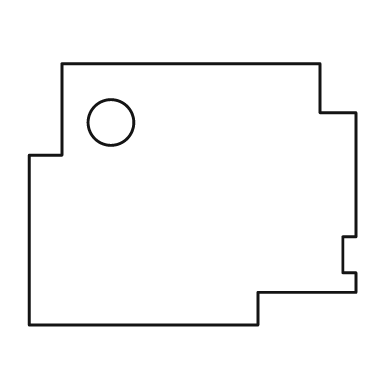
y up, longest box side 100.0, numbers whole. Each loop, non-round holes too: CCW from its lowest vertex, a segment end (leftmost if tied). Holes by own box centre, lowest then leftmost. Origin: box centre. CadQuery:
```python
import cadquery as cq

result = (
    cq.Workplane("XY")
    .moveTo(-50.0, -40.0)
    .lineTo(20.0, -40.0)
    .lineTo(20.0, -30.0)
    .lineTo(50.0, -30.0)
    .lineTo(50.0, -24.0)
    .lineTo(46.0, -24.0)
    .lineTo(46.0, -13.0)
    .lineTo(50.0, -13.0)
    .lineTo(50.0, 25.0)
    .lineTo(39.0, 25.0)
    .lineTo(39.0, 40.0)
    .lineTo(-40.0, 40.0)
    .lineTo(-40.0, 12.0)
    .lineTo(-50.0, 12.0)
    .close()
    .moveTo(-25.0, 22.0)
    .circle(7.0)
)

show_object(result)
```